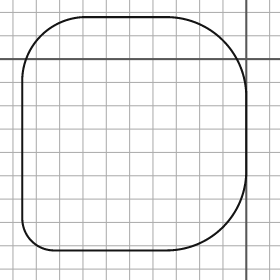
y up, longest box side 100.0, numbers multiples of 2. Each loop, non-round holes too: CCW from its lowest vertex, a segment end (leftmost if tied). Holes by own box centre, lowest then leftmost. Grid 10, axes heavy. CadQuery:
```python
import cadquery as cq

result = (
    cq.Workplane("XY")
    .moveTo(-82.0, -82.0)
    .lineTo(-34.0, -82.0)
    .threePointArc((-10.0, -72.0), (0.0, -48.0))
    .lineTo(0.0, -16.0)
    .threePointArc((-10.0, 8.0), (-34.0, 18.0))
    .lineTo(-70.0, 18.0)
    .threePointArc((-88.0, 10.0), (-96.0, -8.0))
    .lineTo(-96.0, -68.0)
    .threePointArc((-92.0, -78.0), (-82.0, -82.0))
    .close()
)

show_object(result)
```